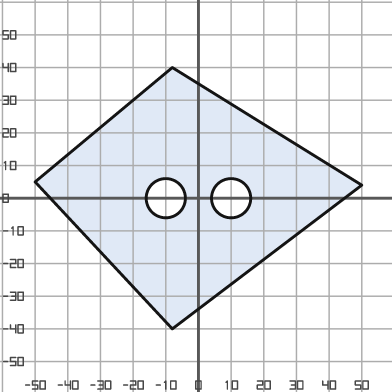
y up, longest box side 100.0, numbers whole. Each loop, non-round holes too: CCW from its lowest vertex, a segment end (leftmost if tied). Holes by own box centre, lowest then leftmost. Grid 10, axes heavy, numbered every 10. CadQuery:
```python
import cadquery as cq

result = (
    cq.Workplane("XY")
    .moveTo(-8.0, -40.0)
    .lineTo(50.0, 4.0)
    .lineTo(-8.0, 40.0)
    .lineTo(-50.0, 5.0)
    .close()
    .moveTo(-10.0, 0.0)
    .circle(6.0)
    .moveTo(10.0, 0.0)
    .circle(6.0)
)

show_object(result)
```